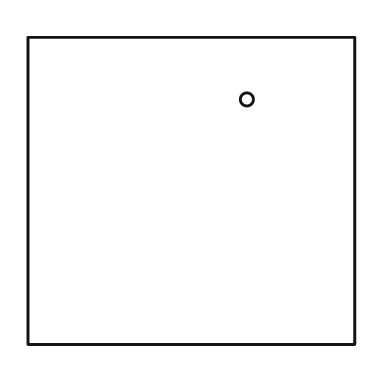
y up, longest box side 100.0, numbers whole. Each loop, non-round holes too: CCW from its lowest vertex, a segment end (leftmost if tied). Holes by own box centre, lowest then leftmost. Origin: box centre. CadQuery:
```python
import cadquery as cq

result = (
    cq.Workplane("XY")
    .moveTo(-50.0, -47.0)
    .lineTo(50.0, -47.0)
    .lineTo(50.0, 47.0)
    .lineTo(-50.0, 47.0)
    .close()
    .moveTo(17.0, 28.0)
    .circle(2.0)
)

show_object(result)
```